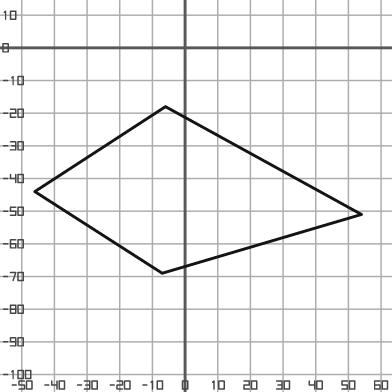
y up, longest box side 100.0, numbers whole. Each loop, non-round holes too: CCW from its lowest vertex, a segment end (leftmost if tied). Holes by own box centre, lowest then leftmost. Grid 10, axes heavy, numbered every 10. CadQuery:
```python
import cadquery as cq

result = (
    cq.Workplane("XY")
    .moveTo(-7.0, -69.0)
    .lineTo(54.0, -51.0)
    .lineTo(-6.0, -18.0)
    .lineTo(-46.0, -44.0)
    .close()
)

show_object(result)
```